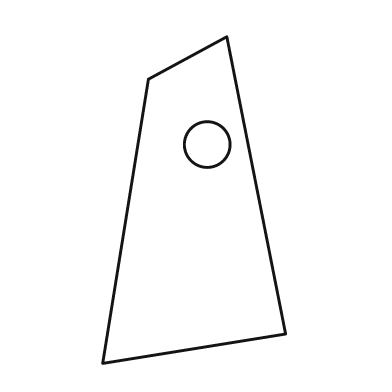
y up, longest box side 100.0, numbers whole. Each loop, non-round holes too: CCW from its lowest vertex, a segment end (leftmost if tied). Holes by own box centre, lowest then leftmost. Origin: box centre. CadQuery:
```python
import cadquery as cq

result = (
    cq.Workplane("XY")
    .moveTo(-28.0, -50.0)
    .lineTo(28.0, -41.0)
    .lineTo(10.0, 50.0)
    .lineTo(-14.0, 37.0)
    .close()
    .moveTo(4.0, 17.0)
    .circle(7.0)
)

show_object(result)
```